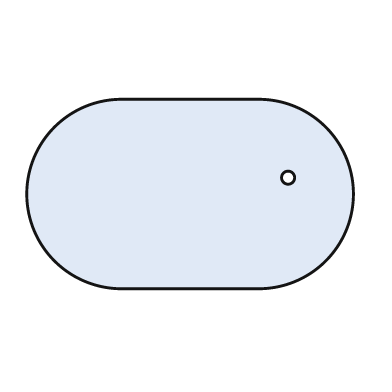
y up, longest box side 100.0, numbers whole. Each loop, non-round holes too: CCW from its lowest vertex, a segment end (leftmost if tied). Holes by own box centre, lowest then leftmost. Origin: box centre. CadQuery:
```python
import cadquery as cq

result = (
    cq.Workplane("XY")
    .moveTo(-21.0, -29.0)
    .lineTo(21.0, -29.0)
    .threePointArc((50.0, 0.0), (21.0, 29.0))
    .lineTo(-21.0, 29.0)
    .threePointArc((-50.0, 0.0), (-21.0, -29.0))
    .close()
    .moveTo(30.0, 5.0)
    .circle(2.0)
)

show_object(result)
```